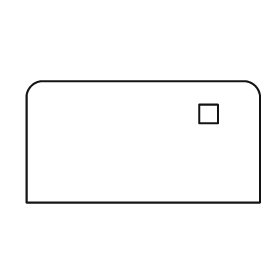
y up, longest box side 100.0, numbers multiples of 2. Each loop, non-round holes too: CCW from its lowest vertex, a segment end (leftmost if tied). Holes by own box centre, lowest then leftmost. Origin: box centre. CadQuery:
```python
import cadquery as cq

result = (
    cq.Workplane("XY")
    .moveTo(-50.0, -26.0)
    .lineTo(50.0, -26.0)
    .lineTo(50.0, 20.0)
    .threePointArc((48.0, 24.0), (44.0, 26.0))
    .lineTo(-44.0, 26.0)
    .threePointArc((-48.0, 24.0), (-50.0, 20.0))
    .close()
    .moveTo(24.0, 8.0)
    .lineTo(32.0, 8.0)
    .lineTo(32.0, 16.0)
    .lineTo(24.0, 16.0)
    .close()
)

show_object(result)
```